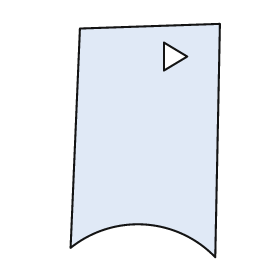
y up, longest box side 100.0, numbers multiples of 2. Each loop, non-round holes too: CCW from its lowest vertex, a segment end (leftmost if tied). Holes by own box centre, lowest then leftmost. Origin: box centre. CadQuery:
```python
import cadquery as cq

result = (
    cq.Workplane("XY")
    .moveTo(30.0, -50.0)
    .lineTo(32.0, 50.0)
    .lineTo(-28.0, 48.0)
    .lineTo(-32.0, -46.0)
    .threePointArc((0.0, -36.0), (30.0, -50.0))
    .close()
    .moveTo(8.0, 30.0)
    .lineTo(18.0, 36.0)
    .lineTo(8.0, 42.0)
    .close()
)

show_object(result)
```